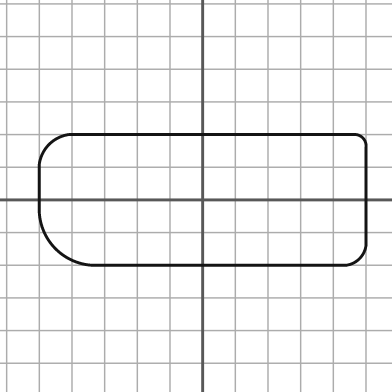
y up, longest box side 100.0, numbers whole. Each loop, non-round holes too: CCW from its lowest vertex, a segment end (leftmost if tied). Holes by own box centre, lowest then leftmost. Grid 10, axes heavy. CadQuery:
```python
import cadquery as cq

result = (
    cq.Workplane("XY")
    .moveTo(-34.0, -20.0)
    .lineTo(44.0, -20.0)
    .threePointArc((48.0, -18.0), (50.0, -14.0))
    .lineTo(50.0, 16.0)
    .threePointArc((49.0, 19.0), (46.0, 20.0))
    .lineTo(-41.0, 20.0)
    .threePointArc((-47.0, 17.0), (-50.0, 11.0))
    .lineTo(-50.0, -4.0)
    .threePointArc((-45.0, -15.0), (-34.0, -20.0))
    .close()
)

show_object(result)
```